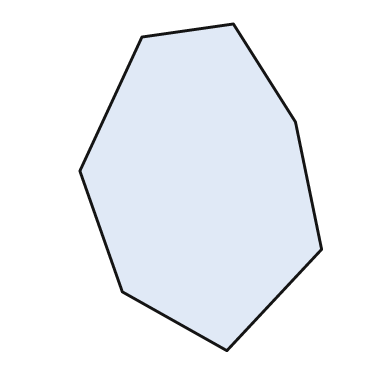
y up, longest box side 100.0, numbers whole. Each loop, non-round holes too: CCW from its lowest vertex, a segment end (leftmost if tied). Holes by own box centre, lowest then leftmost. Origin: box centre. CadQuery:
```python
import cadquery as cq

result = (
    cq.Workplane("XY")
    .moveTo(8.0, -50.0)
    .lineTo(37.0, -19.0)
    .lineTo(29.0, 20.0)
    .lineTo(10.0, 50.0)
    .lineTo(-18.0, 46.0)
    .lineTo(-37.0, 5.0)
    .lineTo(-24.0, -32.0)
    .close()
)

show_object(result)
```